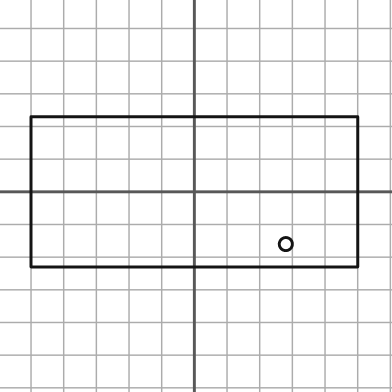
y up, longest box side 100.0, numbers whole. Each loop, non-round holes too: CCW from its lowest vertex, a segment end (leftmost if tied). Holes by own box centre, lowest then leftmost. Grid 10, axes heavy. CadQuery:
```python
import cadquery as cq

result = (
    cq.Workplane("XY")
    .moveTo(-50.0, -23.0)
    .lineTo(50.0, -23.0)
    .lineTo(50.0, 23.0)
    .lineTo(-50.0, 23.0)
    .close()
    .moveTo(28.0, -16.0)
    .circle(2.0)
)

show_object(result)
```